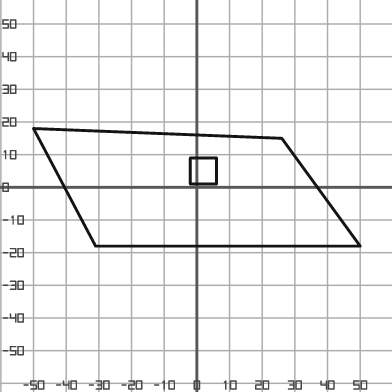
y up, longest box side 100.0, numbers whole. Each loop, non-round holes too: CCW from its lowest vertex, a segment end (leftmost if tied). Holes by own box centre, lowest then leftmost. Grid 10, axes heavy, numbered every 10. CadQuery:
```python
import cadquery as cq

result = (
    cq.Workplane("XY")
    .moveTo(-31.0, -18.0)
    .lineTo(50.0, -18.0)
    .lineTo(26.0, 15.0)
    .lineTo(-50.0, 18.0)
    .close()
    .moveTo(-2.0, 1.0)
    .lineTo(6.0, 1.0)
    .lineTo(6.0, 9.0)
    .lineTo(-2.0, 9.0)
    .close()
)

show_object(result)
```